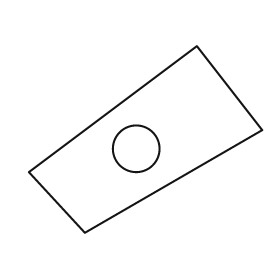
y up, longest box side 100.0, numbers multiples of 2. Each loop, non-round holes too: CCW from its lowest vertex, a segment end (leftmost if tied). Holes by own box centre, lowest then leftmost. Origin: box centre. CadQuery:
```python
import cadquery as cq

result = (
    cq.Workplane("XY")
    .moveTo(-26.0, -40.0)
    .lineTo(50.0, 4.0)
    .lineTo(22.0, 40.0)
    .lineTo(-50.0, -14.0)
    .close()
    .moveTo(-4.0, -4.0)
    .circle(10.0)
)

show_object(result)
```